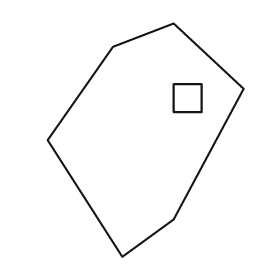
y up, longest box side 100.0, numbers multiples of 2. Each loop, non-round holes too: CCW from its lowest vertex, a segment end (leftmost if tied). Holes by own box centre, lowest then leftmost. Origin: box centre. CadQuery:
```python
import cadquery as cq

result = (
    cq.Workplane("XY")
    .moveTo(-10.0, -50.0)
    .lineTo(12.0, -34.0)
    .lineTo(42.0, 22.0)
    .lineTo(12.0, 50.0)
    .lineTo(-14.0, 40.0)
    .lineTo(-42.0, 0.0)
    .close()
    .moveTo(12.0, 12.0)
    .lineTo(24.0, 12.0)
    .lineTo(24.0, 24.0)
    .lineTo(12.0, 24.0)
    .close()
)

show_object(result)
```